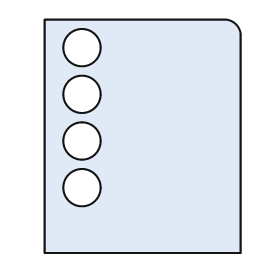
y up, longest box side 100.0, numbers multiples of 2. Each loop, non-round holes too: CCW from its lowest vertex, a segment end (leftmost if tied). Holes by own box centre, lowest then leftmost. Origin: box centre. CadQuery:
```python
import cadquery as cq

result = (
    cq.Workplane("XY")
    .moveTo(-42.0, -50.0)
    .lineTo(42.0, -50.0)
    .lineTo(42.0, 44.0)
    .threePointArc((40.0, 48.0), (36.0, 50.0))
    .lineTo(-42.0, 50.0)
    .close()
    .moveTo(-26.0, -22.0)
    .circle(8.0)
    .moveTo(-26.0, -2.0)
    .circle(8.0)
    .moveTo(-26.0, 18.0)
    .circle(8.0)
    .moveTo(-26.0, 38.0)
    .circle(8.0)
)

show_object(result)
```